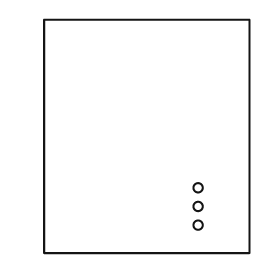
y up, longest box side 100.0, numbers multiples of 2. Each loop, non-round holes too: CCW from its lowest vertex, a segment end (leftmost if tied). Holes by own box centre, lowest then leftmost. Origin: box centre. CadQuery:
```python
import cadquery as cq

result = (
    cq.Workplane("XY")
    .moveTo(-44.0, -50.0)
    .lineTo(44.0, -50.0)
    .lineTo(44.0, 50.0)
    .lineTo(-44.0, 50.0)
    .close()
    .moveTo(22.0, -38.0)
    .circle(2.0)
    .moveTo(22.0, -30.0)
    .circle(2.0)
    .moveTo(22.0, -22.0)
    .circle(2.0)
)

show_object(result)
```